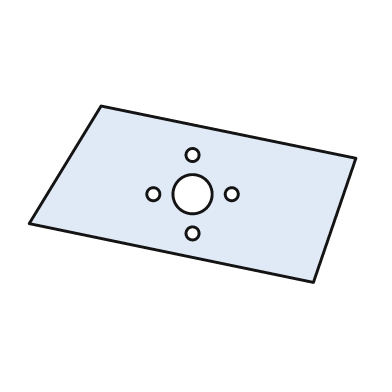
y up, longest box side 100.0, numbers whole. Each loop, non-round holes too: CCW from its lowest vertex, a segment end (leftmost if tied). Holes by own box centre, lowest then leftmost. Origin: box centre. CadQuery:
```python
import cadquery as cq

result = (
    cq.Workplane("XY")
    .moveTo(37.0, -27.0)
    .lineTo(50.0, 11.0)
    .lineTo(-28.0, 27.0)
    .lineTo(-50.0, -9.0)
    .close()
    .moveTo(0.0, -12.0)
    .circle(2.0)
    .moveTo(-12.0, 0.0)
    .circle(2.0)
    .moveTo(0.0, 0.0)
    .circle(6.0)
    .moveTo(12.0, 0.0)
    .circle(2.0)
    .moveTo(0.0, 12.0)
    .circle(2.0)
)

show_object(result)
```